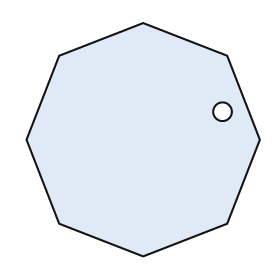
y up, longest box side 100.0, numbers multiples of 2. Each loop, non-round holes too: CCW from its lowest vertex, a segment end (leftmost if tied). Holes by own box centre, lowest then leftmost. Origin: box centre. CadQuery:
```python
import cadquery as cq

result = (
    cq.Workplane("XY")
    .moveTo(0.0, -50.0)
    .lineTo(36.0, -36.0)
    .lineTo(50.0, 0.0)
    .lineTo(36.0, 36.0)
    .lineTo(0.0, 50.0)
    .lineTo(-36.0, 36.0)
    .lineTo(-50.0, 0.0)
    .lineTo(-36.0, -36.0)
    .close()
    .moveTo(34.0, 12.0)
    .circle(4.0)
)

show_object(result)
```